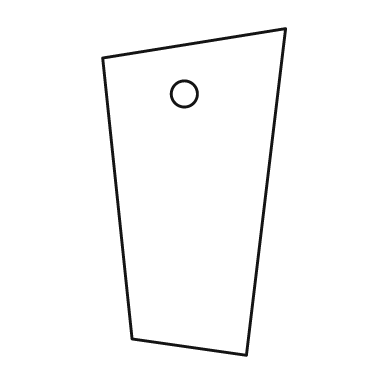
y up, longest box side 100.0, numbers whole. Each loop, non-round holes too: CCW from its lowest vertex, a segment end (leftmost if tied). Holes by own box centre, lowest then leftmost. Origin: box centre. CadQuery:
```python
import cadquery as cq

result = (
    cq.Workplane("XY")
    .moveTo(16.0, -50.0)
    .lineTo(28.0, 50.0)
    .lineTo(-28.0, 41.0)
    .lineTo(-19.0, -45.0)
    .close()
    .moveTo(-3.0, 30.0)
    .circle(4.0)
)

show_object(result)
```